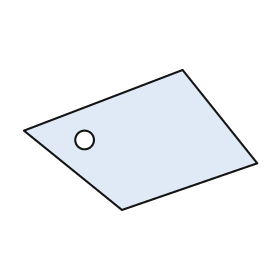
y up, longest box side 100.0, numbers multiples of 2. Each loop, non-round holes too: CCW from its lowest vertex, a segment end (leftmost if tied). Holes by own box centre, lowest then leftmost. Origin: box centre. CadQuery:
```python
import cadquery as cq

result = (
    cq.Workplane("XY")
    .moveTo(-8.0, -30.0)
    .lineTo(50.0, -10.0)
    .lineTo(18.0, 30.0)
    .lineTo(-50.0, 4.0)
    .close()
    .moveTo(-24.0, 0.0)
    .circle(4.0)
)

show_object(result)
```